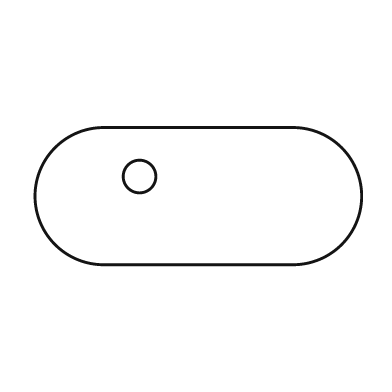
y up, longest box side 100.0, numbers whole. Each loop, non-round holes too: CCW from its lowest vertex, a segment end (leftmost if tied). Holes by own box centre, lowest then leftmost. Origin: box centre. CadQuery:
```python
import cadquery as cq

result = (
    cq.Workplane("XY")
    .moveTo(-29.0, -21.0)
    .lineTo(29.0, -21.0)
    .threePointArc((50.0, 0.0), (29.0, 21.0))
    .lineTo(-29.0, 21.0)
    .threePointArc((-50.0, 0.0), (-29.0, -21.0))
    .close()
    .moveTo(-18.0, 6.0)
    .circle(5.0)
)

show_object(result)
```